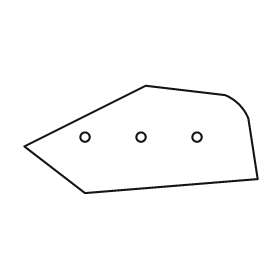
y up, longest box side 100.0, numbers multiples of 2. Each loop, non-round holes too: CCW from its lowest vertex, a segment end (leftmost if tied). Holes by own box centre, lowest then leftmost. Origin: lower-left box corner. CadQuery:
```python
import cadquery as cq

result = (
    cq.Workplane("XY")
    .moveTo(26.0, 0.0)
    .lineTo(100.0, 6.0)
    .lineTo(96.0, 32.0)
    .threePointArc((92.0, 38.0), (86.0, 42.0))
    .lineTo(52.0, 46.0)
    .lineTo(0.0, 20.0)
    .close()
    .moveTo(26.0, 24.0)
    .circle(2.0)
    .moveTo(50.0, 24.0)
    .circle(2.0)
    .moveTo(74.0, 24.0)
    .circle(2.0)
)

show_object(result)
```